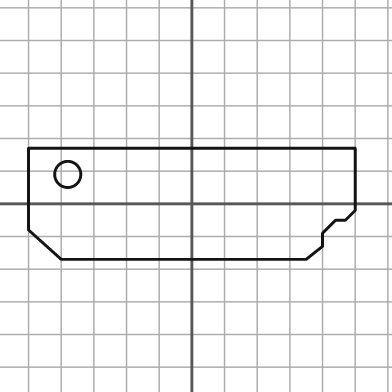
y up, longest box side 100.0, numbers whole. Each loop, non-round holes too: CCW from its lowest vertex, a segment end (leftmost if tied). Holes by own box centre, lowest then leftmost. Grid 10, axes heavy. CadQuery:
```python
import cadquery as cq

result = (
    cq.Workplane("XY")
    .moveTo(-40.0, -17.0)
    .lineTo(35.0, -17.0)
    .lineTo(40.0, -13.0)
    .lineTo(40.0, -9.0)
    .lineTo(44.0, -5.0)
    .lineTo(47.0, -5.0)
    .lineTo(50.0, -2.0)
    .lineTo(50.0, 17.0)
    .lineTo(-50.0, 17.0)
    .lineTo(-50.0, -8.0)
    .close()
    .moveTo(-38.0, 9.0)
    .circle(4.0)
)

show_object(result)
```